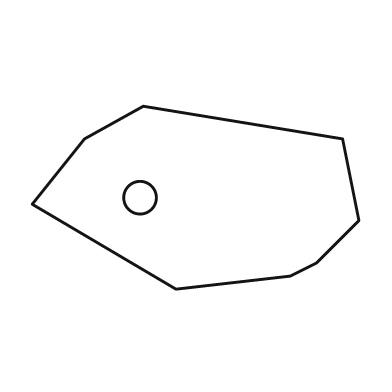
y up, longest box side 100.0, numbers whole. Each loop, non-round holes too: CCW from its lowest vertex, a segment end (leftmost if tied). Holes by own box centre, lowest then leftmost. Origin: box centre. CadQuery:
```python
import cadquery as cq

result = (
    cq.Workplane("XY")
    .moveTo(-6.0, -28.0)
    .lineTo(29.0, -24.0)
    .lineTo(37.0, -20.0)
    .lineTo(50.0, -7.0)
    .lineTo(45.0, 18.0)
    .lineTo(-16.0, 28.0)
    .lineTo(-34.0, 18.0)
    .lineTo(-50.0, -2.0)
    .close()
    .moveTo(-17.0, 0.0)
    .circle(5.0)
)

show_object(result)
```